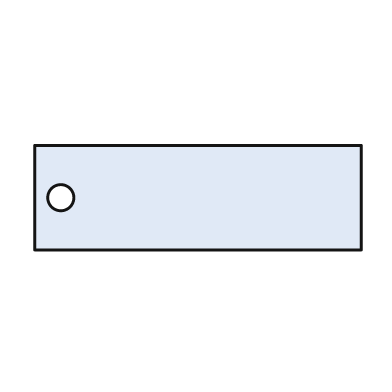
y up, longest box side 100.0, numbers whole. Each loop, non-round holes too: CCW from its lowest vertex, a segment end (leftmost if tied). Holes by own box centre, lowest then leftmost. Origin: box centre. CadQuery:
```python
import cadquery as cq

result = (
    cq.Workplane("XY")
    .moveTo(-50.0, -16.0)
    .lineTo(50.0, -16.0)
    .lineTo(50.0, 16.0)
    .lineTo(-50.0, 16.0)
    .close()
    .moveTo(-42.0, 0.0)
    .circle(4.0)
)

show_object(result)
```